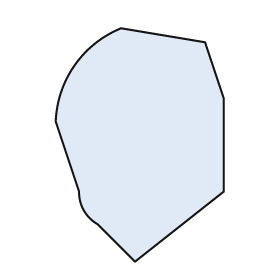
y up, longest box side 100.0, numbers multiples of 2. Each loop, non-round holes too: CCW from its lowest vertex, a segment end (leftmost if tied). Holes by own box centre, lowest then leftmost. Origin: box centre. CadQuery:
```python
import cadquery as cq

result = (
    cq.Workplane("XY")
    .moveTo(-2.0, -50.0)
    .lineTo(36.0, -20.0)
    .lineTo(36.0, 20.0)
    .lineTo(28.0, 44.0)
    .lineTo(-8.0, 50.0)
    .threePointArc((-28.0, 34.0), (-36.0, 10.0))
    .lineTo(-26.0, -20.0)
    .threePointArc((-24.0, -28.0), (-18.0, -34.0))
    .close()
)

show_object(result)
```